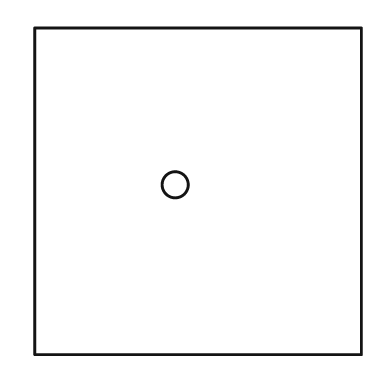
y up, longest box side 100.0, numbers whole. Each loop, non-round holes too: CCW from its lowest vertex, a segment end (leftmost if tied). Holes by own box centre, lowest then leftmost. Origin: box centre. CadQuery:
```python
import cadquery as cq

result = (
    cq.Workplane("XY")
    .moveTo(-50.0, -50.0)
    .lineTo(50.0, -50.0)
    .lineTo(50.0, 50.0)
    .lineTo(-50.0, 50.0)
    .close()
    .moveTo(-7.0, 2.0)
    .circle(4.0)
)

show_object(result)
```